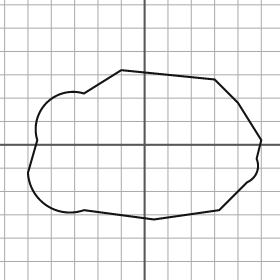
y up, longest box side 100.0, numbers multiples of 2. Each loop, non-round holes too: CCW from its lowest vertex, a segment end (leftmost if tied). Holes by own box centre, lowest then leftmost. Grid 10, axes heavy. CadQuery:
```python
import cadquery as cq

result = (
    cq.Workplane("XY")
    .moveTo(4.0, -32.0)
    .lineTo(32.0, -28.0)
    .lineTo(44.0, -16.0)
    .threePointArc((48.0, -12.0), (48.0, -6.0))
    .lineTo(50.0, 2.0)
    .lineTo(40.0, 18.0)
    .lineTo(30.0, 28.0)
    .lineTo(-10.0, 32.0)
    .lineTo(-26.0, 22.0)
    .threePointArc((-42.0, 18.0), (-46.0, 2.0))
    .lineTo(-50.0, -12.0)
    .threePointArc((-42.0, -26.0), (-26.0, -28.0))
    .close()
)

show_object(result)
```